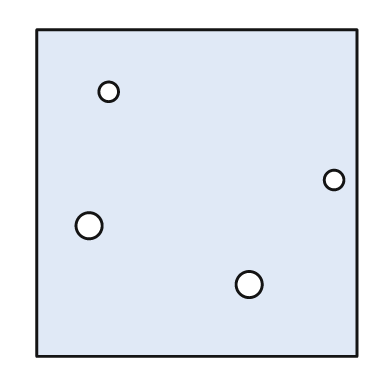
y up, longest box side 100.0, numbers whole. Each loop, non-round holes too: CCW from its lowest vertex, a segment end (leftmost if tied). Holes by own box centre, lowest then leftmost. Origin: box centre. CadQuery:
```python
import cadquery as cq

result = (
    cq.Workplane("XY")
    .moveTo(-49.0, -50.0)
    .lineTo(49.0, -50.0)
    .lineTo(49.0, 50.0)
    .lineTo(-49.0, 50.0)
    .close()
    .moveTo(16.0, -28.0)
    .circle(4.0)
    .moveTo(-33.0, -10.0)
    .circle(4.0)
    .moveTo(42.0, 4.0)
    .circle(3.0)
    .moveTo(-27.0, 31.0)
    .circle(3.0)
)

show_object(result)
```